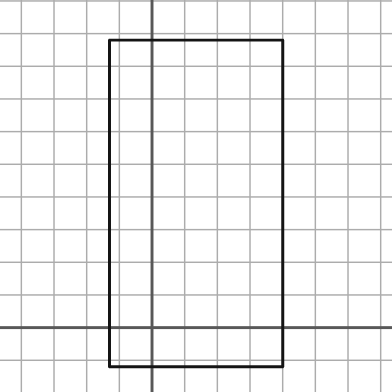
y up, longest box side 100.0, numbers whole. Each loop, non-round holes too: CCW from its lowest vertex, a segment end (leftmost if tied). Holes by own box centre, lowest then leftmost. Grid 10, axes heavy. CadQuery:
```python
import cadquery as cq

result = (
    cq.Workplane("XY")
    .moveTo(-13.0, -12.0)
    .lineTo(40.0, -12.0)
    .lineTo(40.0, 88.0)
    .lineTo(-13.0, 88.0)
    .close()
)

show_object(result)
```